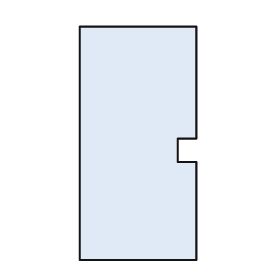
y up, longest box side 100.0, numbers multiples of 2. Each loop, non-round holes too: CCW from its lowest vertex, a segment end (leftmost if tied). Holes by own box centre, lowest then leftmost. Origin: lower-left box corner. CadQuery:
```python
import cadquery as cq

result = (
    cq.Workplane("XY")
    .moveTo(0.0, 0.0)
    .lineTo(50.0, 0.0)
    .lineTo(50.0, 42.0)
    .lineTo(42.0, 42.0)
    .lineTo(42.0, 52.0)
    .lineTo(50.0, 52.0)
    .lineTo(50.0, 100.0)
    .lineTo(0.0, 100.0)
    .close()
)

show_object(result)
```